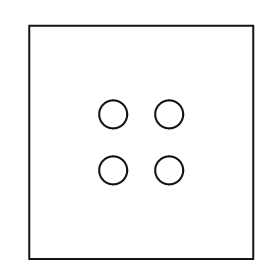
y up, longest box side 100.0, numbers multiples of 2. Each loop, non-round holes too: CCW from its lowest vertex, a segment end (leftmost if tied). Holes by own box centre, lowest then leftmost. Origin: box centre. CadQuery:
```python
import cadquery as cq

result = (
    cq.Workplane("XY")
    .moveTo(-48.0, -50.0)
    .lineTo(48.0, -50.0)
    .lineTo(48.0, 50.0)
    .lineTo(-48.0, 50.0)
    .close()
    .moveTo(-12.0, -12.0)
    .circle(6.0)
    .moveTo(12.0, -12.0)
    .circle(6.0)
    .moveTo(-12.0, 12.0)
    .circle(6.0)
    .moveTo(12.0, 12.0)
    .circle(6.0)
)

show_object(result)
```